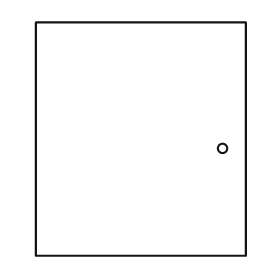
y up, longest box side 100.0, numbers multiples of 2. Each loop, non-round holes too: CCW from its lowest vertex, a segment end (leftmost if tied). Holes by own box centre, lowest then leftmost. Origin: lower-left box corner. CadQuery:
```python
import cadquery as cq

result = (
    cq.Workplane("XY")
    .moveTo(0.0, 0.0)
    .lineTo(90.0, 0.0)
    .lineTo(90.0, 100.0)
    .lineTo(0.0, 100.0)
    .close()
    .moveTo(80.0, 46.0)
    .circle(2.0)
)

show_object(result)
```